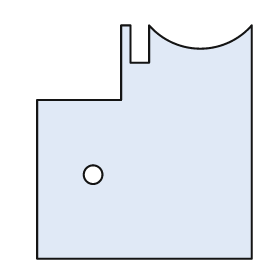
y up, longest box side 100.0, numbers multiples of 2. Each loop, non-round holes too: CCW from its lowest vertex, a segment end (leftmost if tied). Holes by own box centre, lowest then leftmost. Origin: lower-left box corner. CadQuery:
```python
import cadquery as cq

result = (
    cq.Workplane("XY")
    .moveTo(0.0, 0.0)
    .lineTo(92.0, 0.0)
    .lineTo(92.0, 100.0)
    .threePointArc((70.0, 90.0), (48.0, 100.0))
    .lineTo(48.0, 84.0)
    .lineTo(40.0, 84.0)
    .lineTo(40.0, 100.0)
    .lineTo(36.0, 100.0)
    .lineTo(36.0, 68.0)
    .lineTo(0.0, 68.0)
    .close()
    .moveTo(24.0, 36.0)
    .circle(4.0)
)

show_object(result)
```